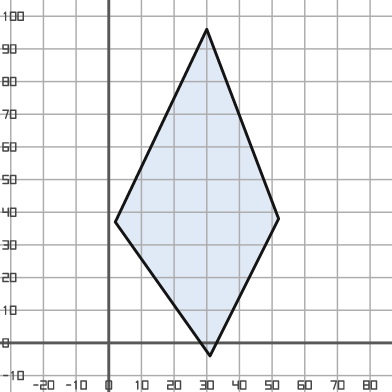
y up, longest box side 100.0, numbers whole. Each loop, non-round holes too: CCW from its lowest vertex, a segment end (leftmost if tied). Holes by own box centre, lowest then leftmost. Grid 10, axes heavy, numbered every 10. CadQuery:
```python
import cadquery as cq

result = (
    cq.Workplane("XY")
    .moveTo(31.0, -4.0)
    .lineTo(52.0, 38.0)
    .lineTo(30.0, 96.0)
    .lineTo(2.0, 37.0)
    .close()
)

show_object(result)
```